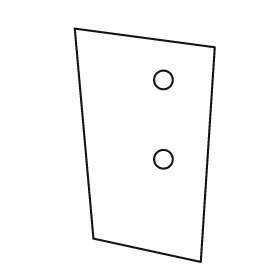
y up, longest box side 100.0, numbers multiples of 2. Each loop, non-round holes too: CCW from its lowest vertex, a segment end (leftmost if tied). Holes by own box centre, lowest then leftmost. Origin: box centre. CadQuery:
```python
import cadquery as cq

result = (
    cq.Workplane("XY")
    .moveTo(24.0, -50.0)
    .lineTo(30.0, 42.0)
    .lineTo(-30.0, 50.0)
    .lineTo(-22.0, -40.0)
    .close()
    .moveTo(8.0, -6.0)
    .circle(4.0)
    .moveTo(8.0, 28.0)
    .circle(4.0)
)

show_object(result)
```